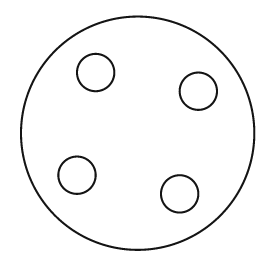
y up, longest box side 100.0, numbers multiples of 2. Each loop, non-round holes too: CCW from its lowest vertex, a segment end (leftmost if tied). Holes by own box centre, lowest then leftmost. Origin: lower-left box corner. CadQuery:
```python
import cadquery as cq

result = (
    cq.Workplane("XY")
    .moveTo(50.0, 50.0)
    .circle(50.0)
    .moveTo(68.0, 24.0)
    .circle(8.0)
    .moveTo(24.0, 32.0)
    .circle(8.0)
    .moveTo(76.0, 68.0)
    .circle(8.0)
    .moveTo(32.0, 76.0)
    .circle(8.0)
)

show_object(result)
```